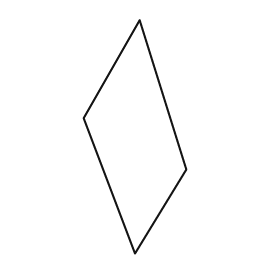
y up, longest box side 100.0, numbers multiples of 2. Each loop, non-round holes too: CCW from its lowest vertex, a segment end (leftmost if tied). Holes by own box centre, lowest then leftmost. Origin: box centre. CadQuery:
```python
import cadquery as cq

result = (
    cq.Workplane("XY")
    .moveTo(0.0, -50.0)
    .lineTo(22.0, -14.0)
    .lineTo(2.0, 50.0)
    .lineTo(-22.0, 8.0)
    .close()
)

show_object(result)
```